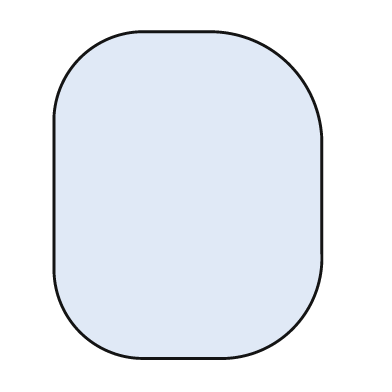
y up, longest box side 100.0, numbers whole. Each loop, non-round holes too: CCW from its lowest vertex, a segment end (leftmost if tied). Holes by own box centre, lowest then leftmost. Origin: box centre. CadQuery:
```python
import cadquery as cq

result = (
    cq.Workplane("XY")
    .moveTo(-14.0, -50.0)
    .lineTo(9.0, -50.0)
    .threePointArc((32.0, -41.0), (41.0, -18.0))
    .lineTo(41.0, 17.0)
    .threePointArc((31.0, 40.0), (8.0, 50.0))
    .lineTo(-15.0, 50.0)
    .threePointArc((-33.0, 42.0), (-41.0, 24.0))
    .lineTo(-41.0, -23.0)
    .threePointArc((-33.0, -42.0), (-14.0, -50.0))
    .close()
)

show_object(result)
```